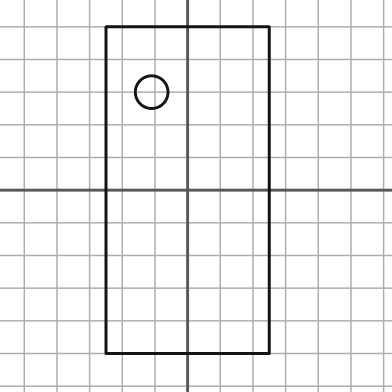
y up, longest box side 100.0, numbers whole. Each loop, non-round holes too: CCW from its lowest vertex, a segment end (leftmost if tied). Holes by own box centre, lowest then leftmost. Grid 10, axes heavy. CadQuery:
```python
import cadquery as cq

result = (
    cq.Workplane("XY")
    .moveTo(-25.0, -50.0)
    .lineTo(25.0, -50.0)
    .lineTo(25.0, 50.0)
    .lineTo(-25.0, 50.0)
    .close()
    .moveTo(-11.0, 30.0)
    .circle(5.0)
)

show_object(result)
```